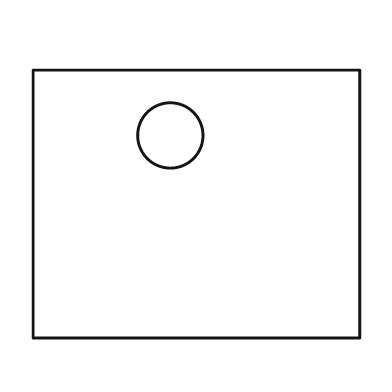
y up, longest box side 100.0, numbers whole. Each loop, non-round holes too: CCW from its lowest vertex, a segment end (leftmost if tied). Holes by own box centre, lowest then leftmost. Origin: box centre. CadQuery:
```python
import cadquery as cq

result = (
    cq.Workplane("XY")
    .moveTo(-50.0, -41.0)
    .lineTo(50.0, -41.0)
    .lineTo(50.0, 41.0)
    .lineTo(-50.0, 41.0)
    .close()
    .moveTo(-8.0, 21.0)
    .circle(10.0)
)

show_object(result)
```